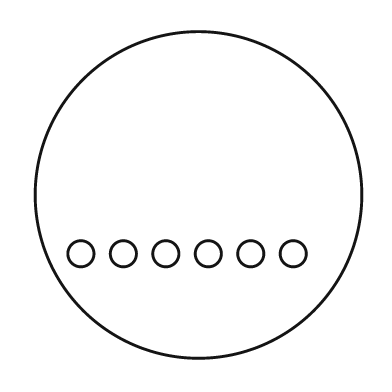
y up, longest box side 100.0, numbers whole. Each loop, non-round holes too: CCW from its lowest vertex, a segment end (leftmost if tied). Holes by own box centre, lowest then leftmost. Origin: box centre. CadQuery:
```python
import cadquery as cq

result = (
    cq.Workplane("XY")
    .moveTo(0.0, 0.0)
    .circle(50.0)
    .moveTo(-36.0, -18.0)
    .circle(4.0)
    .moveTo(-23.0, -18.0)
    .circle(4.0)
    .moveTo(-10.0, -18.0)
    .circle(4.0)
    .moveTo(3.0, -18.0)
    .circle(4.0)
    .moveTo(16.0, -18.0)
    .circle(4.0)
    .moveTo(29.0, -18.0)
    .circle(4.0)
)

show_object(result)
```